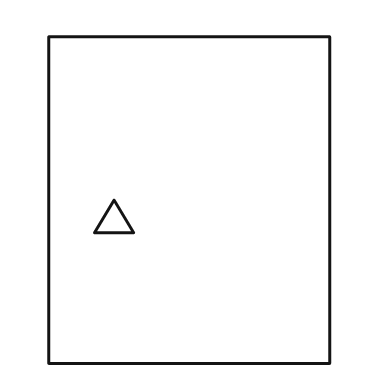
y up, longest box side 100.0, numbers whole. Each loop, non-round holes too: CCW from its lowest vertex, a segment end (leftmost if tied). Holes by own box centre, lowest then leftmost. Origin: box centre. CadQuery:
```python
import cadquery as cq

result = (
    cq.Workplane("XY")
    .moveTo(-43.0, -50.0)
    .lineTo(43.0, -50.0)
    .lineTo(43.0, 50.0)
    .lineTo(-43.0, 50.0)
    .close()
    .moveTo(-29.0, -10.0)
    .lineTo(-17.0, -10.0)
    .lineTo(-23.0, 0.0)
    .close()
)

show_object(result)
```